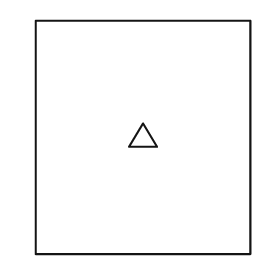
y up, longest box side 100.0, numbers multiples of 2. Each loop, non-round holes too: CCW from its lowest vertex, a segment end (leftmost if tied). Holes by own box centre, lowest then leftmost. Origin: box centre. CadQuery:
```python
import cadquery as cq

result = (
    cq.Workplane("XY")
    .moveTo(-46.0, -50.0)
    .lineTo(46.0, -50.0)
    .lineTo(46.0, 50.0)
    .lineTo(-46.0, 50.0)
    .close()
    .moveTo(-6.0, -4.0)
    .lineTo(6.0, -4.0)
    .lineTo(0.0, 6.0)
    .close()
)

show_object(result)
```